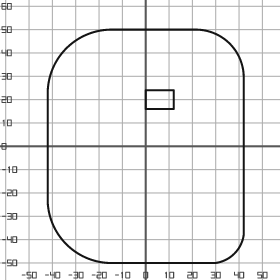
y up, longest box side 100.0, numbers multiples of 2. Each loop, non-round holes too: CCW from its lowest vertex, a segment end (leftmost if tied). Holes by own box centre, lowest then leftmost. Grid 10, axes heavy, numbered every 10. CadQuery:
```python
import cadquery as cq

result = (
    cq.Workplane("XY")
    .moveTo(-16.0, -50.0)
    .lineTo(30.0, -50.0)
    .threePointArc((38.0, -46.0), (42.0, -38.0))
    .lineTo(42.0, 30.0)
    .threePointArc((36.0, 44.0), (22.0, 50.0))
    .lineTo(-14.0, 50.0)
    .threePointArc((-34.0, 42.0), (-42.0, 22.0))
    .lineTo(-42.0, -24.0)
    .threePointArc((-34.0, -42.0), (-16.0, -50.0))
    .close()
    .moveTo(0.0, 16.0)
    .lineTo(12.0, 16.0)
    .lineTo(12.0, 24.0)
    .lineTo(0.0, 24.0)
    .close()
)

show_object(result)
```